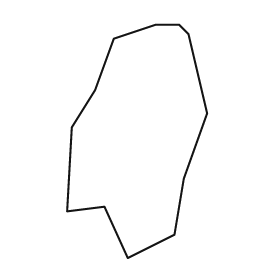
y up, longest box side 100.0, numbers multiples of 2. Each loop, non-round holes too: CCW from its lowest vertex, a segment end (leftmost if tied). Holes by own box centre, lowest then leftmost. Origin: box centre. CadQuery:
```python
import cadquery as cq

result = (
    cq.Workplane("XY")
    .moveTo(-4.0, -50.0)
    .lineTo(16.0, -40.0)
    .lineTo(20.0, -16.0)
    .lineTo(30.0, 12.0)
    .lineTo(22.0, 46.0)
    .lineTo(18.0, 50.0)
    .lineTo(8.0, 50.0)
    .lineTo(-10.0, 44.0)
    .lineTo(-18.0, 22.0)
    .lineTo(-28.0, 6.0)
    .lineTo(-30.0, -30.0)
    .lineTo(-14.0, -28.0)
    .close()
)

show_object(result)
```